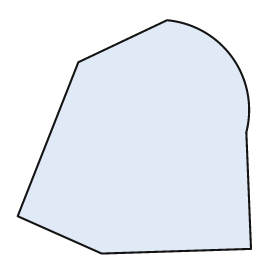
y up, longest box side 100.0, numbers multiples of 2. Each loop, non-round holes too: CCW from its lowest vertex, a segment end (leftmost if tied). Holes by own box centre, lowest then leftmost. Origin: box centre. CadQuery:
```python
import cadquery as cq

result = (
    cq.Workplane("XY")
    .moveTo(-14.0, -50.0)
    .lineTo(50.0, -48.0)
    .lineTo(48.0, 2.0)
    .threePointArc((42.0, 34.0), (14.0, 50.0))
    .lineTo(-24.0, 32.0)
    .lineTo(-50.0, -34.0)
    .close()
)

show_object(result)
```